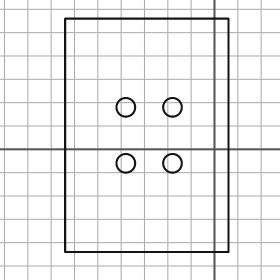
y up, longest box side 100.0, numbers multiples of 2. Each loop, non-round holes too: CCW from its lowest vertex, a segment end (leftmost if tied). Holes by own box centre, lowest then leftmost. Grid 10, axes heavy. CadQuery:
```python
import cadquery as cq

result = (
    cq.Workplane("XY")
    .moveTo(-64.0, -44.0)
    .lineTo(6.0, -44.0)
    .lineTo(6.0, 56.0)
    .lineTo(-64.0, 56.0)
    .close()
    .moveTo(-38.0, -6.0)
    .circle(4.0)
    .moveTo(-18.0, -6.0)
    .circle(4.0)
    .moveTo(-38.0, 18.0)
    .circle(4.0)
    .moveTo(-18.0, 18.0)
    .circle(4.0)
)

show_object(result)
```